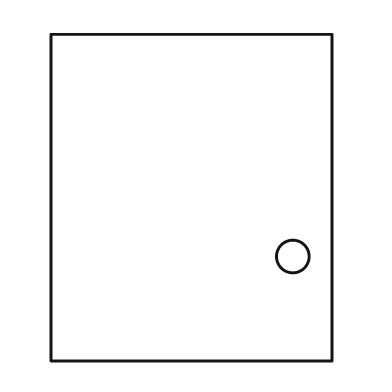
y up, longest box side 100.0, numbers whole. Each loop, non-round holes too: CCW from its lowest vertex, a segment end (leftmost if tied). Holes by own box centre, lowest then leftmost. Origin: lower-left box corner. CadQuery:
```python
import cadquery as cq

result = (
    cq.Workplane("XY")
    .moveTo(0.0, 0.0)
    .lineTo(86.0, 0.0)
    .lineTo(86.0, 100.0)
    .lineTo(0.0, 100.0)
    .close()
    .moveTo(74.0, 32.0)
    .circle(5.0)
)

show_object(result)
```